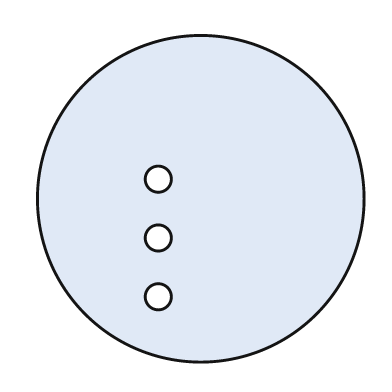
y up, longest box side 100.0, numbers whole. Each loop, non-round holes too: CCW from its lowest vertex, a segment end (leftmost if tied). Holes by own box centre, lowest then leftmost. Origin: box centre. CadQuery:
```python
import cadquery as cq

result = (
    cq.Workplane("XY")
    .moveTo(0.0, 0.0)
    .circle(50.0)
    .moveTo(-13.0, -30.0)
    .circle(4.0)
    .moveTo(-13.0, -12.0)
    .circle(4.0)
    .moveTo(-13.0, 6.0)
    .circle(4.0)
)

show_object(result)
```